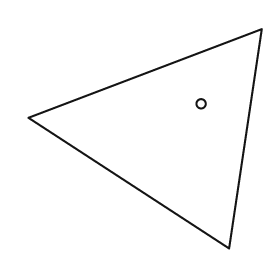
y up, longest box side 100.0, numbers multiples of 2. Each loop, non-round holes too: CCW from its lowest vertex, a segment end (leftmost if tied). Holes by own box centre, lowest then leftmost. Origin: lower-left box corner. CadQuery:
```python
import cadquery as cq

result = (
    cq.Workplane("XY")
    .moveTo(86.0, 0.0)
    .lineTo(100.0, 94.0)
    .lineTo(0.0, 56.0)
    .close()
    .moveTo(74.0, 62.0)
    .circle(2.0)
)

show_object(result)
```